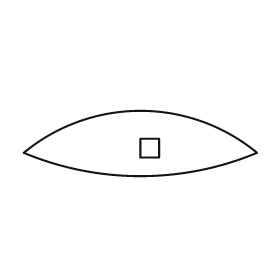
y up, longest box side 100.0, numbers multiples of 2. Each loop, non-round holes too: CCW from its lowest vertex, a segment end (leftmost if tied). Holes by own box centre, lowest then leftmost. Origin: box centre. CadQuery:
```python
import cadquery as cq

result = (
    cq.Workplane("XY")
    .moveTo(-50.0, -4.0)
    .threePointArc((0.0, -14.0), (50.0, -4.0))
    .threePointArc((0.0, 14.0), (-50.0, -4.0))
    .close()
    .moveTo(0.0, -6.0)
    .lineTo(8.0, -6.0)
    .lineTo(8.0, 2.0)
    .lineTo(0.0, 2.0)
    .close()
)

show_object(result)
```